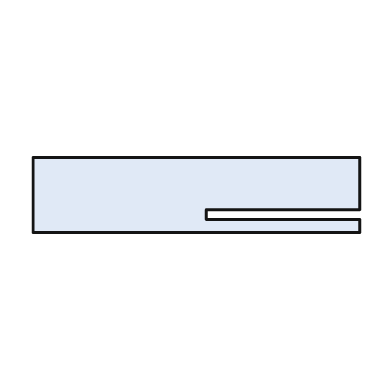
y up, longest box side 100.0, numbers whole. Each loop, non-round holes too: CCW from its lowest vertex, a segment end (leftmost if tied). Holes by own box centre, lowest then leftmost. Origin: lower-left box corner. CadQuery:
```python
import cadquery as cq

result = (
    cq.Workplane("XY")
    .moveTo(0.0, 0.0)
    .lineTo(100.0, 0.0)
    .lineTo(100.0, 4.0)
    .lineTo(53.0, 4.0)
    .lineTo(53.0, 7.0)
    .lineTo(100.0, 7.0)
    .lineTo(100.0, 23.0)
    .lineTo(0.0, 23.0)
    .close()
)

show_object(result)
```